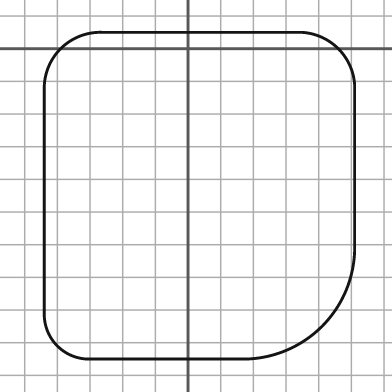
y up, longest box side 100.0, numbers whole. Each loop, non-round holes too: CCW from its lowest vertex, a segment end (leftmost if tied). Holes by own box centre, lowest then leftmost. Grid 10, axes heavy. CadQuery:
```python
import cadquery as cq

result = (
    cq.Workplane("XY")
    .moveTo(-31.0, -95.0)
    .lineTo(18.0, -95.0)
    .threePointArc((41.0, -85.0), (51.0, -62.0))
    .lineTo(51.0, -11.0)
    .threePointArc((46.0, 0.0), (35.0, 5.0))
    .lineTo(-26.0, 5.0)
    .threePointArc((-39.0, 0.0), (-44.0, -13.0))
    .lineTo(-44.0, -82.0)
    .threePointArc((-40.0, -91.0), (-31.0, -95.0))
    .close()
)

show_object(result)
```